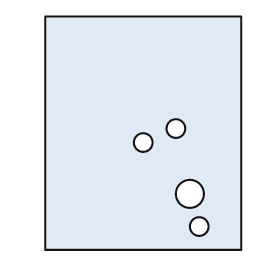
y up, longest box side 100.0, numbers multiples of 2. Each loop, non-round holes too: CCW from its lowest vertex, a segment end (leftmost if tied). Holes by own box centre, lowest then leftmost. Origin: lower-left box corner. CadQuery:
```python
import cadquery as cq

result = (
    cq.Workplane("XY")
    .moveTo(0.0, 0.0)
    .lineTo(84.0, 0.0)
    .lineTo(84.0, 100.0)
    .lineTo(0.0, 100.0)
    .close()
    .moveTo(66.0, 10.0)
    .circle(4.0)
    .moveTo(62.0, 24.0)
    .circle(6.0)
    .moveTo(42.0, 46.0)
    .circle(4.0)
    .moveTo(56.0, 52.0)
    .circle(4.0)
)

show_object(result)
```